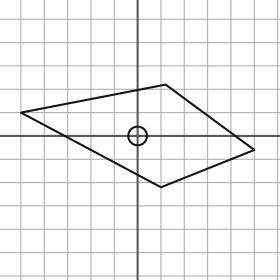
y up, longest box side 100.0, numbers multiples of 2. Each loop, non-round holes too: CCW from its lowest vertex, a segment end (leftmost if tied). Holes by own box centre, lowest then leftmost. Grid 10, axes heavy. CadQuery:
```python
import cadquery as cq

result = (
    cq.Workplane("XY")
    .moveTo(10.0, -22.0)
    .lineTo(50.0, -6.0)
    .lineTo(12.0, 22.0)
    .lineTo(-50.0, 10.0)
    .close()
    .moveTo(0.0, 0.0)
    .circle(4.0)
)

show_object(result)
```